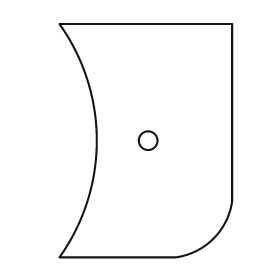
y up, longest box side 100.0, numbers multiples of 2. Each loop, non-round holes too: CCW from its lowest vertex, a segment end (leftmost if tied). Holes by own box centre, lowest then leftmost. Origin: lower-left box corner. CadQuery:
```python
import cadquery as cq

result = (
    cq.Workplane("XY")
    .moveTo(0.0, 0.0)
    .lineTo(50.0, 0.0)
    .threePointArc((66.0, 8.0), (74.0, 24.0))
    .lineTo(74.0, 100.0)
    .lineTo(0.0, 100.0)
    .threePointArc((16.0, 50.0), (0.0, 0.0))
    .close()
    .moveTo(38.0, 50.0)
    .circle(4.0)
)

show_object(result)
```